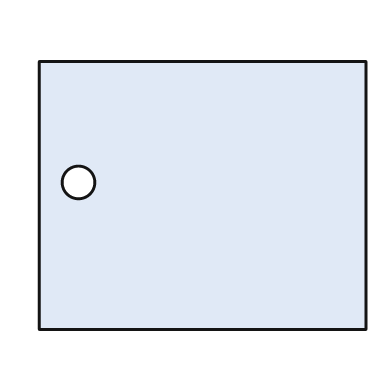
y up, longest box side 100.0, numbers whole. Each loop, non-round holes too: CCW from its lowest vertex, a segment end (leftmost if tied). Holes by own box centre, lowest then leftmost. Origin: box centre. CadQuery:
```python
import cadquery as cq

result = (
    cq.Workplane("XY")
    .moveTo(-50.0, -41.0)
    .lineTo(50.0, -41.0)
    .lineTo(50.0, 41.0)
    .lineTo(-50.0, 41.0)
    .close()
    .moveTo(-38.0, 4.0)
    .circle(5.0)
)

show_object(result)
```